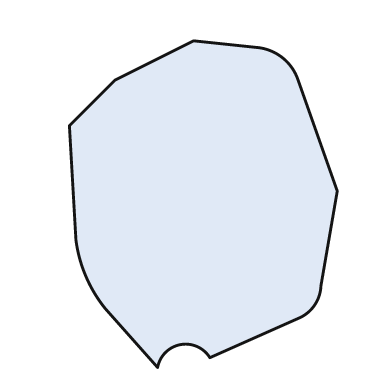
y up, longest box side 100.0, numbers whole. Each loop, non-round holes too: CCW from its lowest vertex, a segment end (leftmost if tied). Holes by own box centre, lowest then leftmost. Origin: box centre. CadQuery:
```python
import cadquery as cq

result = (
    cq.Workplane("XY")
    .moveTo(-14.0, -50.0)
    .threePointArc((-7.0, -43.0), (2.0, -47.0))
    .lineTo(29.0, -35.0)
    .threePointArc((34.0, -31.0), (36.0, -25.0))
    .lineTo(41.0, 4.0)
    .lineTo(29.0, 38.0)
    .threePointArc((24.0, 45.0), (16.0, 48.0))
    .lineTo(-3.0, 50.0)
    .lineTo(-27.0, 38.0)
    .lineTo(-41.0, 24.0)
    .lineTo(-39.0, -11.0)
    .threePointArc((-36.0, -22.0), (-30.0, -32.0))
    .close()
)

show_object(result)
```